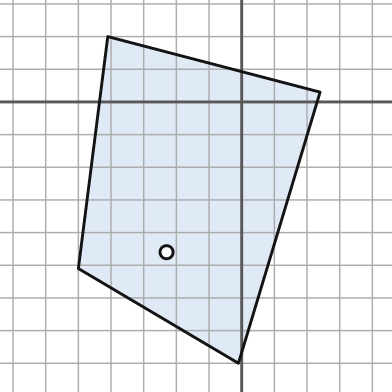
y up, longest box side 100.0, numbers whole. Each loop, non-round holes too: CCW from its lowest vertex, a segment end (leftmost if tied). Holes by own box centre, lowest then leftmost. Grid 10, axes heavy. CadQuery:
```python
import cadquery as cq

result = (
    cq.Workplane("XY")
    .moveTo(-1.0, -80.0)
    .lineTo(24.0, 3.0)
    .lineTo(-41.0, 20.0)
    .lineTo(-50.0, -51.0)
    .close()
    .moveTo(-23.0, -46.0)
    .circle(2.0)
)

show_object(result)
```